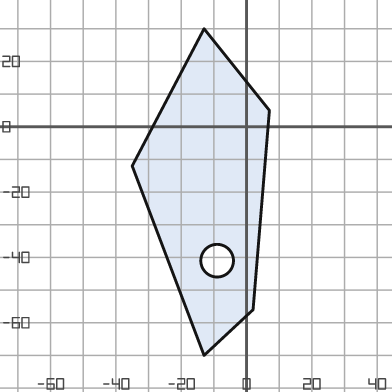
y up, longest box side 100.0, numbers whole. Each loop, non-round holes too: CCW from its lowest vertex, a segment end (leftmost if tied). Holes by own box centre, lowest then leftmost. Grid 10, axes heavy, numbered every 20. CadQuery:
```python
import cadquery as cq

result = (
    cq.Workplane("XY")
    .moveTo(-13.0, -70.0)
    .lineTo(2.0, -56.0)
    .lineTo(7.0, 5.0)
    .lineTo(-13.0, 30.0)
    .lineTo(-35.0, -12.0)
    .close()
    .moveTo(-9.0, -41.0)
    .circle(5.0)
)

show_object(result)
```